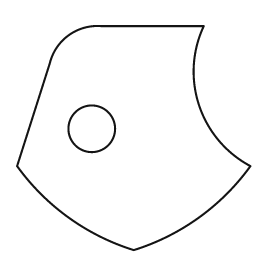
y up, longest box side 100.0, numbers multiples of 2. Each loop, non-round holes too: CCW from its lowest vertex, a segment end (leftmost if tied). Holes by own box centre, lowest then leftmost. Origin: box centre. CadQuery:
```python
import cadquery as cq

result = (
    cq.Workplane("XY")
    .moveTo(0.0, -48.0)
    .threePointArc((28.0, -34.0), (50.0, -12.0))
    .threePointArc((28.0, 14.0), (30.0, 48.0))
    .lineTo(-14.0, 48.0)
    .threePointArc((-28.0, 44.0), (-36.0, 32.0))
    .lineTo(-50.0, -12.0)
    .threePointArc((-28.0, -34.0), (0.0, -48.0))
    .close()
    .moveTo(-18.0, 4.0)
    .circle(10.0)
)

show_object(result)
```